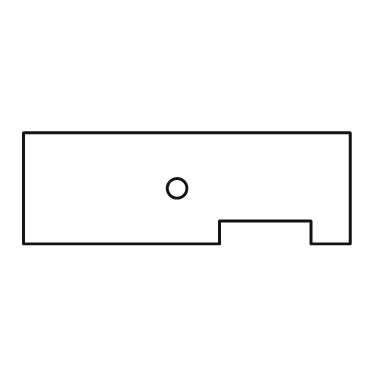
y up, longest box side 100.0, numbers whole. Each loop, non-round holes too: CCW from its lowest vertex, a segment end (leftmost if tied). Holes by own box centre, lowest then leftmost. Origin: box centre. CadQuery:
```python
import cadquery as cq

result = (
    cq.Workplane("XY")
    .moveTo(-50.0, -17.0)
    .lineTo(10.0, -17.0)
    .lineTo(10.0, -10.0)
    .lineTo(38.0, -10.0)
    .lineTo(38.0, -17.0)
    .lineTo(50.0, -17.0)
    .lineTo(50.0, 17.0)
    .lineTo(-50.0, 17.0)
    .close()
    .moveTo(-3.0, 0.0)
    .circle(3.0)
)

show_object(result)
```